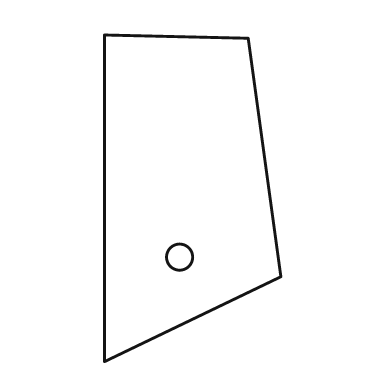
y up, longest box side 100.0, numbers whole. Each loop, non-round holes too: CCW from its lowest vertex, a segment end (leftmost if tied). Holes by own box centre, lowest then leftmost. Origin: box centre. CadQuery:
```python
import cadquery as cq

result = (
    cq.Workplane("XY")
    .moveTo(-27.0, -50.0)
    .lineTo(27.0, -24.0)
    .lineTo(17.0, 49.0)
    .lineTo(-27.0, 50.0)
    .close()
    .moveTo(-4.0, -18.0)
    .circle(4.0)
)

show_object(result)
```